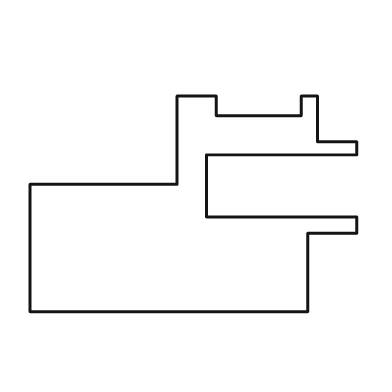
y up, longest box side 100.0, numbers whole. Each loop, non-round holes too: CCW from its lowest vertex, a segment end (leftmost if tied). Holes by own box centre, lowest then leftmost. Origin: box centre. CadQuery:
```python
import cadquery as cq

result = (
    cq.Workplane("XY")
    .moveTo(-50.0, -33.0)
    .lineTo(35.0, -33.0)
    .lineTo(35.0, -9.0)
    .lineTo(50.0, -9.0)
    .lineTo(50.0, -4.0)
    .lineTo(4.0, -4.0)
    .lineTo(4.0, 15.0)
    .lineTo(50.0, 15.0)
    .lineTo(50.0, 19.0)
    .lineTo(38.0, 19.0)
    .lineTo(38.0, 33.0)
    .lineTo(33.0, 33.0)
    .lineTo(33.0, 27.0)
    .lineTo(7.0, 27.0)
    .lineTo(7.0, 33.0)
    .lineTo(-5.0, 33.0)
    .lineTo(-5.0, 6.0)
    .lineTo(-50.0, 6.0)
    .close()
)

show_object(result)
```